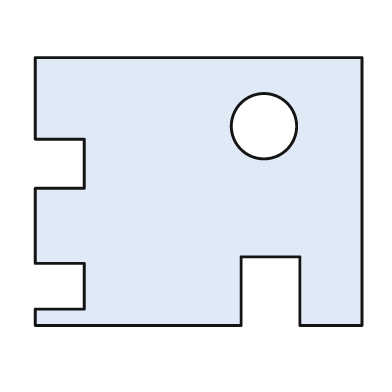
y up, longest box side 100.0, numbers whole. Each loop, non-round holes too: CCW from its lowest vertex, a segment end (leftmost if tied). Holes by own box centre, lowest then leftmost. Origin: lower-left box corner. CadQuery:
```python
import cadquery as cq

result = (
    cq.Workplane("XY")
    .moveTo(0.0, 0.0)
    .lineTo(63.0, 0.0)
    .lineTo(63.0, 21.0)
    .lineTo(81.0, 21.0)
    .lineTo(81.0, 0.0)
    .lineTo(100.0, 0.0)
    .lineTo(100.0, 82.0)
    .lineTo(0.0, 82.0)
    .lineTo(0.0, 57.0)
    .lineTo(15.0, 57.0)
    .lineTo(15.0, 42.0)
    .lineTo(0.0, 42.0)
    .lineTo(0.0, 19.0)
    .lineTo(15.0, 19.0)
    .lineTo(15.0, 5.0)
    .lineTo(0.0, 5.0)
    .close()
    .moveTo(70.0, 61.0)
    .circle(10.0)
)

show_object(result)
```